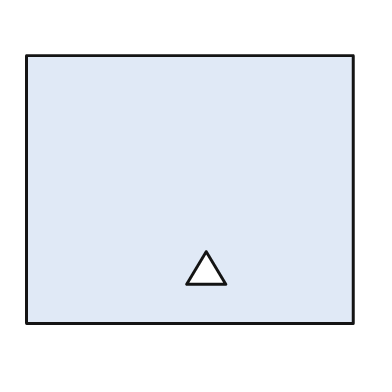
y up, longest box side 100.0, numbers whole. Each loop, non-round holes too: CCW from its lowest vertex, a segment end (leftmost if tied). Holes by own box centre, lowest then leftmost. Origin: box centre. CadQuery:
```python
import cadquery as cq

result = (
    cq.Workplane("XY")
    .moveTo(-50.0, -41.0)
    .lineTo(50.0, -41.0)
    .lineTo(50.0, 41.0)
    .lineTo(-50.0, 41.0)
    .close()
    .moveTo(-1.0, -29.0)
    .lineTo(11.0, -29.0)
    .lineTo(5.0, -19.0)
    .close()
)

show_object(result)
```